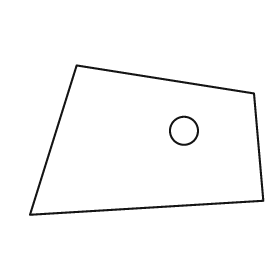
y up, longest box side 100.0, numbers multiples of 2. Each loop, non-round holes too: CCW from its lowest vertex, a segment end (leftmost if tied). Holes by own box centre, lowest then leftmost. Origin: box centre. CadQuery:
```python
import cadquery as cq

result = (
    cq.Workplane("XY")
    .moveTo(-50.0, -32.0)
    .lineTo(50.0, -26.0)
    .lineTo(46.0, 20.0)
    .lineTo(-30.0, 32.0)
    .close()
    .moveTo(16.0, 4.0)
    .circle(6.0)
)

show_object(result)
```